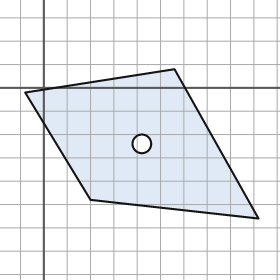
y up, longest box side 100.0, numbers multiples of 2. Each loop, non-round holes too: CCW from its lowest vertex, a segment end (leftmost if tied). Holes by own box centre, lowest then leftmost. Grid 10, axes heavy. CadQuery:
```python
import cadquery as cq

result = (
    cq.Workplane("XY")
    .moveTo(92.0, -56.0)
    .lineTo(56.0, 8.0)
    .lineTo(-8.0, -2.0)
    .lineTo(20.0, -48.0)
    .close()
    .moveTo(42.0, -24.0)
    .circle(4.0)
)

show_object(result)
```